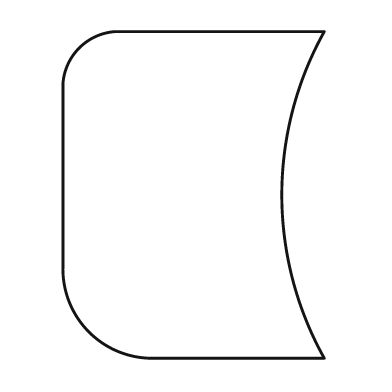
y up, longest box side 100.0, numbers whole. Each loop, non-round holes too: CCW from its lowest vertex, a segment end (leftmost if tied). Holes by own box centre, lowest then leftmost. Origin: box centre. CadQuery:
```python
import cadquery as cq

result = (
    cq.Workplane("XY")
    .moveTo(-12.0, -50.0)
    .lineTo(40.0, -50.0)
    .threePointArc((27.0, 0.0), (40.0, 50.0))
    .lineTo(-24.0, 50.0)
    .threePointArc((-35.0, 45.0), (-40.0, 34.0))
    .lineTo(-40.0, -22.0)
    .threePointArc((-32.0, -42.0), (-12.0, -50.0))
    .close()
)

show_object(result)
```